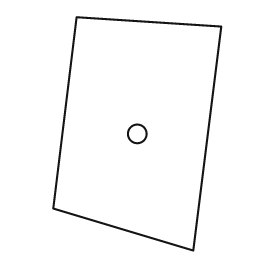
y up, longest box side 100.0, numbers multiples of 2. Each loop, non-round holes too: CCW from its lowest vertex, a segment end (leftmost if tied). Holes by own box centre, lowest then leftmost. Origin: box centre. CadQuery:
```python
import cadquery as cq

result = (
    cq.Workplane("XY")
    .moveTo(24.0, -50.0)
    .lineTo(36.0, 46.0)
    .lineTo(-26.0, 50.0)
    .lineTo(-36.0, -32.0)
    .close()
    .moveTo(0.0, 0.0)
    .circle(4.0)
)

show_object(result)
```